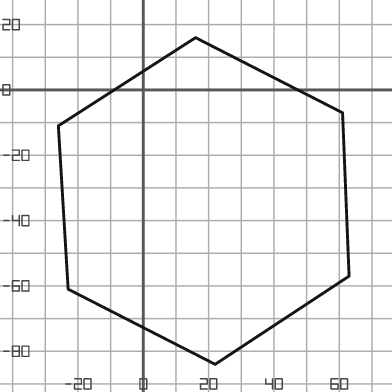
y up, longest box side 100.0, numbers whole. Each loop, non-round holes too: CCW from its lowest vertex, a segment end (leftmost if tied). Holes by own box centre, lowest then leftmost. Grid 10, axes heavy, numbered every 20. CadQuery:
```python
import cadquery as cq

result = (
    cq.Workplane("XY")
    .moveTo(22.0, -84.0)
    .lineTo(63.0, -57.0)
    .lineTo(61.0, -7.0)
    .lineTo(16.0, 16.0)
    .lineTo(-26.0, -11.0)
    .lineTo(-23.0, -61.0)
    .close()
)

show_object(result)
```